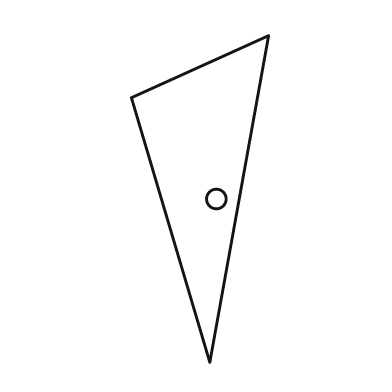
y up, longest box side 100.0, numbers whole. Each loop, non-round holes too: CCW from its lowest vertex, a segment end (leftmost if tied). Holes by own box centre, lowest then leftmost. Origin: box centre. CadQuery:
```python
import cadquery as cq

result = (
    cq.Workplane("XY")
    .moveTo(3.0, -50.0)
    .lineTo(21.0, 50.0)
    .lineTo(-21.0, 31.0)
    .close()
    .moveTo(5.0, 0.0)
    .circle(3.0)
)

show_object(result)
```